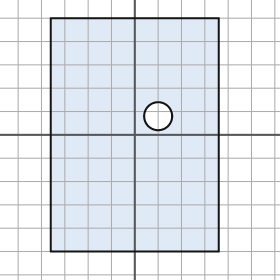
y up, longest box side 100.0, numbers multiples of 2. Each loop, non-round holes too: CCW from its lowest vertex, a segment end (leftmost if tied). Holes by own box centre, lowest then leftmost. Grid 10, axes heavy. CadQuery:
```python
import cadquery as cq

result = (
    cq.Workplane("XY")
    .moveTo(-36.0, -50.0)
    .lineTo(36.0, -50.0)
    .lineTo(36.0, 50.0)
    .lineTo(-36.0, 50.0)
    .close()
    .moveTo(10.0, 8.0)
    .circle(6.0)
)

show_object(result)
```